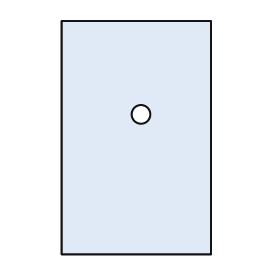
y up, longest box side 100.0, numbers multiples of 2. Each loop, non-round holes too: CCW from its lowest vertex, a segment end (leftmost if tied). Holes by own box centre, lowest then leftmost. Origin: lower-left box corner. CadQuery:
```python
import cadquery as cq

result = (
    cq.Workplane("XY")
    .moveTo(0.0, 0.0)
    .lineTo(64.0, 0.0)
    .lineTo(64.0, 100.0)
    .lineTo(0.0, 100.0)
    .close()
    .moveTo(34.0, 60.0)
    .circle(4.0)
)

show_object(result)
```